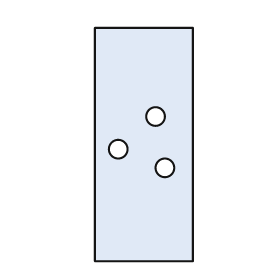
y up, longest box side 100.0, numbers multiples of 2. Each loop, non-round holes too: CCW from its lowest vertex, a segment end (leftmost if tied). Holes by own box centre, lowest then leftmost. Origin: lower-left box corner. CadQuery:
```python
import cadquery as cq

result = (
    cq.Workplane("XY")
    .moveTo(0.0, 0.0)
    .lineTo(42.0, 0.0)
    .lineTo(42.0, 100.0)
    .lineTo(0.0, 100.0)
    .close()
    .moveTo(30.0, 40.0)
    .circle(4.0)
    .moveTo(10.0, 48.0)
    .circle(4.0)
    .moveTo(26.0, 62.0)
    .circle(4.0)
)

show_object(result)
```